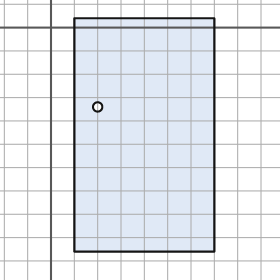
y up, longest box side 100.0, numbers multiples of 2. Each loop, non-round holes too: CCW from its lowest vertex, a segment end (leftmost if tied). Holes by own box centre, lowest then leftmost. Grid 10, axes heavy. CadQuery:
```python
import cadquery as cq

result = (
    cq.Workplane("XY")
    .moveTo(10.0, -96.0)
    .lineTo(70.0, -96.0)
    .lineTo(70.0, 4.0)
    .lineTo(10.0, 4.0)
    .close()
    .moveTo(20.0, -34.0)
    .circle(2.0)
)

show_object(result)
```